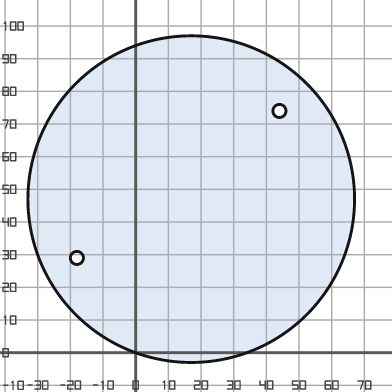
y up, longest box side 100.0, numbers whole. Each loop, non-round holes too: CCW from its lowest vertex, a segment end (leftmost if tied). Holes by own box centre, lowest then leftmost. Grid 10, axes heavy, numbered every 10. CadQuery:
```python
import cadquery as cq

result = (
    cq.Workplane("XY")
    .moveTo(17.0, 47.0)
    .circle(50.0)
    .moveTo(-18.0, 29.0)
    .circle(2.0)
    .moveTo(44.0, 74.0)
    .circle(2.0)
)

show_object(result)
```